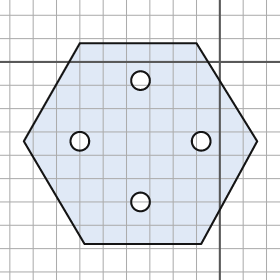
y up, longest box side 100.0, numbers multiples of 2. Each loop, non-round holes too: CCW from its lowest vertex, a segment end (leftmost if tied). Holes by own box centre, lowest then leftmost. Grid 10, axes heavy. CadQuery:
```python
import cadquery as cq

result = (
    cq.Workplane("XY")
    .moveTo(-58.0, -78.0)
    .lineTo(-8.0, -78.0)
    .lineTo(16.0, -34.0)
    .lineTo(-10.0, 8.0)
    .lineTo(-60.0, 8.0)
    .lineTo(-84.0, -34.0)
    .close()
    .moveTo(-34.0, -60.0)
    .circle(4.0)
    .moveTo(-60.0, -34.0)
    .circle(4.0)
    .moveTo(-8.0, -34.0)
    .circle(4.0)
    .moveTo(-34.0, -8.0)
    .circle(4.0)
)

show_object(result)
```